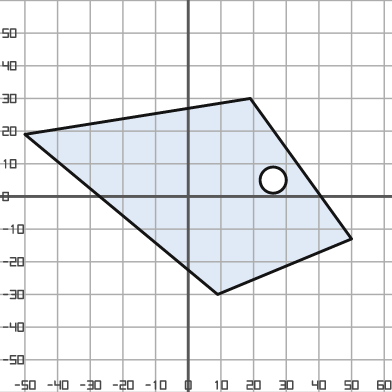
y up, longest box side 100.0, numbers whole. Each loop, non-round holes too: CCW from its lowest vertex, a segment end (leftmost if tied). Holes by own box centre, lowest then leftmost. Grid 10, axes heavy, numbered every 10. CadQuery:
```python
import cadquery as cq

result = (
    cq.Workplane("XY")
    .moveTo(9.0, -30.0)
    .lineTo(50.0, -13.0)
    .lineTo(19.0, 30.0)
    .lineTo(-50.0, 19.0)
    .close()
    .moveTo(26.0, 5.0)
    .circle(4.0)
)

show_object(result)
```